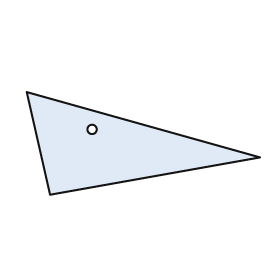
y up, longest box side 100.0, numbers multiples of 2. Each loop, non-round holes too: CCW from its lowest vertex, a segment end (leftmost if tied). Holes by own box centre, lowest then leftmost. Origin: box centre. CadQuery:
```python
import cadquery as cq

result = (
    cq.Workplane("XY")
    .moveTo(-40.0, -22.0)
    .lineTo(50.0, -6.0)
    .lineTo(-50.0, 22.0)
    .close()
    .moveTo(-22.0, 6.0)
    .circle(2.0)
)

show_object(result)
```